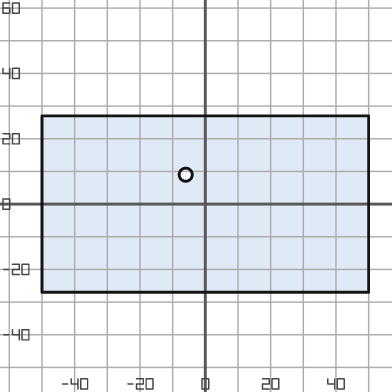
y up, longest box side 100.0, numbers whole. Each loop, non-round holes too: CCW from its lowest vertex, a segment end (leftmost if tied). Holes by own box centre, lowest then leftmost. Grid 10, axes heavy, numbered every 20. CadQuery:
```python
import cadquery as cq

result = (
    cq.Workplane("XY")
    .moveTo(-50.0, -27.0)
    .lineTo(50.0, -27.0)
    .lineTo(50.0, 27.0)
    .lineTo(-50.0, 27.0)
    .close()
    .moveTo(-6.0, 9.0)
    .circle(2.0)
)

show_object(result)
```